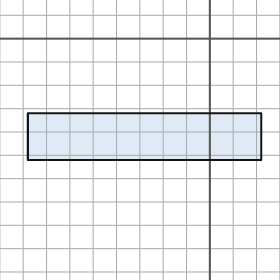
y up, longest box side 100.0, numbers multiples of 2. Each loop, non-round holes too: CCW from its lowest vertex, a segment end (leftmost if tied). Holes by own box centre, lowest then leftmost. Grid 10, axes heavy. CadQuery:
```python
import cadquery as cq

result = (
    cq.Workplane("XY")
    .moveTo(-78.0, -52.0)
    .lineTo(22.0, -52.0)
    .lineTo(22.0, -32.0)
    .lineTo(-78.0, -32.0)
    .close()
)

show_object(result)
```